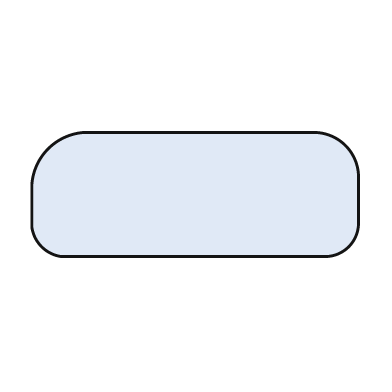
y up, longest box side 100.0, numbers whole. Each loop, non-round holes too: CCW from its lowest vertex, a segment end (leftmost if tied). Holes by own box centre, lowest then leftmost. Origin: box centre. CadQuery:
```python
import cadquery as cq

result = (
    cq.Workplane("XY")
    .moveTo(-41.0, -19.0)
    .lineTo(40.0, -19.0)
    .threePointArc((47.0, -16.0), (50.0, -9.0))
    .lineTo(50.0, 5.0)
    .threePointArc((46.0, 15.0), (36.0, 19.0))
    .lineTo(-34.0, 19.0)
    .threePointArc((-45.0, 14.0), (-50.0, 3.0))
    .lineTo(-50.0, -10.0)
    .threePointArc((-47.0, -16.0), (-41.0, -19.0))
    .close()
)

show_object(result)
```